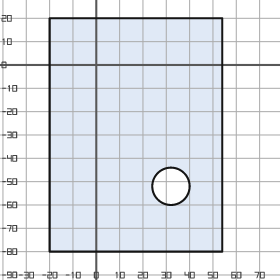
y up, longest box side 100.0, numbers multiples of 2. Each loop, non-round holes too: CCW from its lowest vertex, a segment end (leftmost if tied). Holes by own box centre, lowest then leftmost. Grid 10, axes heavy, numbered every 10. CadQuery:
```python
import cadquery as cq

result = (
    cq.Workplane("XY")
    .moveTo(-20.0, -80.0)
    .lineTo(54.0, -80.0)
    .lineTo(54.0, 20.0)
    .lineTo(-20.0, 20.0)
    .close()
    .moveTo(32.0, -52.0)
    .circle(8.0)
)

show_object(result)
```